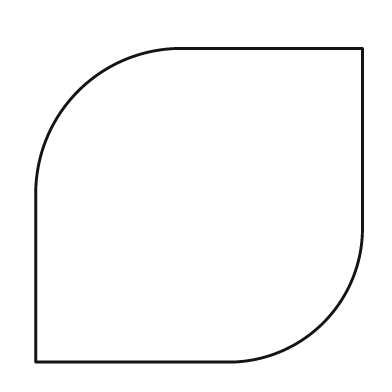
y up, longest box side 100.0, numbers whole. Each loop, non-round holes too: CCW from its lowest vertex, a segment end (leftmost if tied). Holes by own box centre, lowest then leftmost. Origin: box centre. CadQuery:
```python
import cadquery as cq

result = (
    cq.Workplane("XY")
    .moveTo(-50.0, -48.0)
    .lineTo(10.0, -48.0)
    .threePointArc((38.0, -36.0), (50.0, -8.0))
    .lineTo(50.0, 48.0)
    .lineTo(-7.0, 48.0)
    .threePointArc((-37.0, 35.0), (-50.0, 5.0))
    .close()
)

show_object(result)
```